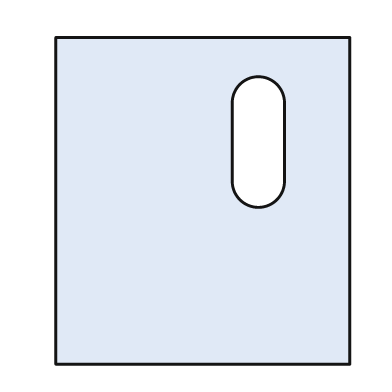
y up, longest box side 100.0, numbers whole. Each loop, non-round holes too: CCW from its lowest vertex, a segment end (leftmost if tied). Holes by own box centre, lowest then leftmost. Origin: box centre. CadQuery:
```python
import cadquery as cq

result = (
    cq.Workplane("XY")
    .moveTo(-45.0, -50.0)
    .lineTo(45.0, -50.0)
    .lineTo(45.0, 50.0)
    .lineTo(-45.0, 50.0)
    .close()
    .moveTo(9.0, 6.0)
    .threePointArc((17.0, -2.0), (25.0, 6.0))
    .lineTo(25.0, 30.0)
    .threePointArc((17.0, 38.0), (9.0, 30.0))
    .close()
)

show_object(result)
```